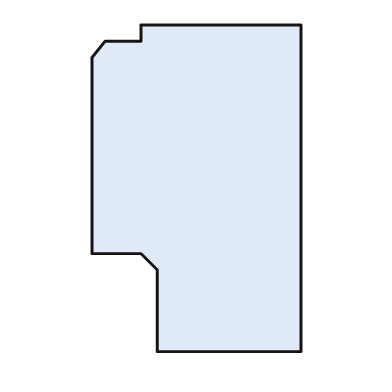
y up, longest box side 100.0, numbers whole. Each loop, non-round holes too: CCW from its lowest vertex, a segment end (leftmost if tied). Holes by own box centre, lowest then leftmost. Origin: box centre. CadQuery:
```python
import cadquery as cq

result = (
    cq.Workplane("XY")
    .moveTo(-12.0, -50.0)
    .lineTo(32.0, -50.0)
    .lineTo(32.0, 50.0)
    .lineTo(-17.0, 50.0)
    .lineTo(-17.0, 45.0)
    .lineTo(-28.0, 45.0)
    .lineTo(-32.0, 40.0)
    .lineTo(-32.0, -20.0)
    .lineTo(-17.0, -20.0)
    .lineTo(-12.0, -25.0)
    .close()
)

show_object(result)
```